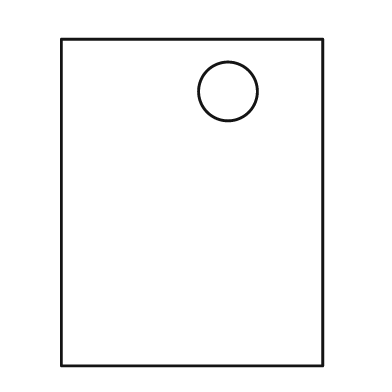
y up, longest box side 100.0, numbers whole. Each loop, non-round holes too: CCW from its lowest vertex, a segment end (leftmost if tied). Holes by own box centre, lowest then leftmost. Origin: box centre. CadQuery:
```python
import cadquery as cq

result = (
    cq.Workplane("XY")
    .moveTo(-40.0, -50.0)
    .lineTo(40.0, -50.0)
    .lineTo(40.0, 50.0)
    .lineTo(-40.0, 50.0)
    .close()
    .moveTo(11.0, 34.0)
    .circle(9.0)
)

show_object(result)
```